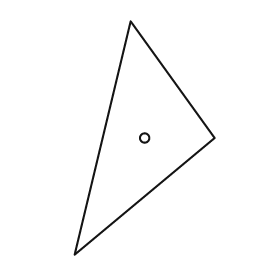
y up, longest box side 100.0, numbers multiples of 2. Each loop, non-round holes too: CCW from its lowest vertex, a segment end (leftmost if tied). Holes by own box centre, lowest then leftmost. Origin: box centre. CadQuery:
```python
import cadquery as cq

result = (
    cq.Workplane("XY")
    .moveTo(-30.0, -50.0)
    .lineTo(30.0, 0.0)
    .lineTo(-6.0, 50.0)
    .close()
    .moveTo(0.0, 0.0)
    .circle(2.0)
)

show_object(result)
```